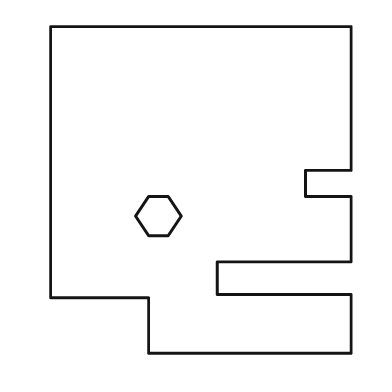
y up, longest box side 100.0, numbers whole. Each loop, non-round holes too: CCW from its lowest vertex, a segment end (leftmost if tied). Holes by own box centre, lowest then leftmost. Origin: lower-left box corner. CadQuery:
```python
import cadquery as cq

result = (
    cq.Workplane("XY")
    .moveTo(30.0, 0.0)
    .lineTo(92.0, 0.0)
    .lineTo(92.0, 18.0)
    .lineTo(51.0, 18.0)
    .lineTo(51.0, 28.0)
    .lineTo(92.0, 28.0)
    .lineTo(92.0, 48.0)
    .lineTo(78.0, 48.0)
    .lineTo(78.0, 56.0)
    .lineTo(92.0, 56.0)
    .lineTo(92.0, 100.0)
    .lineTo(0.0, 100.0)
    .lineTo(0.0, 17.0)
    .lineTo(30.0, 17.0)
    .close()
    .moveTo(30.0, 36.0)
    .lineTo(36.0, 36.0)
    .lineTo(40.0, 42.0)
    .lineTo(36.0, 48.0)
    .lineTo(30.0, 48.0)
    .lineTo(26.0, 42.0)
    .close()
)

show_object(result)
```